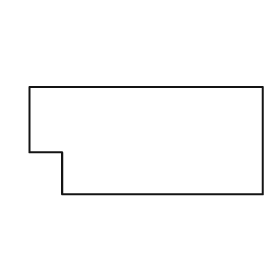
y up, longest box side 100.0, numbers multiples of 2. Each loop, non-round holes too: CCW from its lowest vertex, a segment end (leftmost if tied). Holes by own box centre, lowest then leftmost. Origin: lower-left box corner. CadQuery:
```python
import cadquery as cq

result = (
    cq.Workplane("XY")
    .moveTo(14.0, 0.0)
    .lineTo(100.0, 0.0)
    .lineTo(100.0, 46.0)
    .lineTo(0.0, 46.0)
    .lineTo(0.0, 18.0)
    .lineTo(14.0, 18.0)
    .close()
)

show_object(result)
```